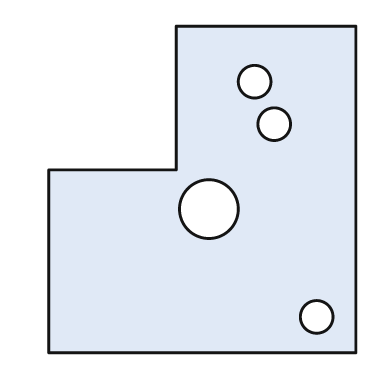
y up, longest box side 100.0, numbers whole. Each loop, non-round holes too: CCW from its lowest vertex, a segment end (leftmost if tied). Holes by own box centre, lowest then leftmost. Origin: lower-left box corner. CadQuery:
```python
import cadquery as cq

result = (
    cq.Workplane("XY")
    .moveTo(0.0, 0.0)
    .lineTo(94.0, 0.0)
    .lineTo(94.0, 100.0)
    .lineTo(39.0, 100.0)
    .lineTo(39.0, 56.0)
    .lineTo(0.0, 56.0)
    .close()
    .moveTo(82.0, 11.0)
    .circle(5.0)
    .moveTo(49.0, 44.0)
    .circle(9.0)
    .moveTo(69.0, 70.0)
    .circle(5.0)
    .moveTo(63.0, 83.0)
    .circle(5.0)
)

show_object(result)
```